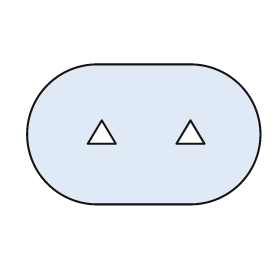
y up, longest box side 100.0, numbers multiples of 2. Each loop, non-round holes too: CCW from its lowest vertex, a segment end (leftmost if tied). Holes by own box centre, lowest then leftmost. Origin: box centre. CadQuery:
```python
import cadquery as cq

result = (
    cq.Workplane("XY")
    .moveTo(-20.0, -30.0)
    .lineTo(20.0, -30.0)
    .threePointArc((50.0, 0.0), (20.0, 30.0))
    .lineTo(-20.0, 30.0)
    .threePointArc((-50.0, 0.0), (-20.0, -30.0))
    .close()
    .moveTo(-24.0, -4.0)
    .lineTo(-12.0, -4.0)
    .lineTo(-18.0, 6.0)
    .close()
    .moveTo(14.0, -4.0)
    .lineTo(26.0, -4.0)
    .lineTo(20.0, 6.0)
    .close()
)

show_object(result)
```